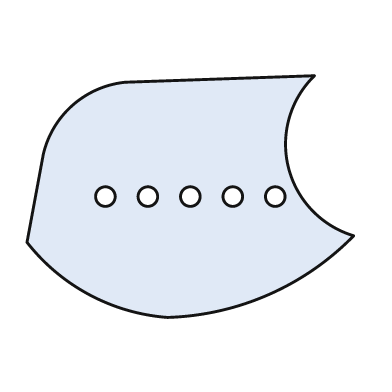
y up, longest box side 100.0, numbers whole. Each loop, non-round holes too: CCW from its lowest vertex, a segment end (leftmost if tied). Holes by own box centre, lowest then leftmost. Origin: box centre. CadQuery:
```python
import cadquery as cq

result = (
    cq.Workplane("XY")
    .moveTo(-7.0, -37.0)
    .threePointArc((24.0, -30.0), (50.0, -12.0))
    .threePointArc((30.0, 9.0), (38.0, 37.0))
    .lineTo(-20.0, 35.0)
    .threePointArc((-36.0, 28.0), (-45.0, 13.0))
    .lineTo(-50.0, -14.0)
    .threePointArc((-31.0, -30.0), (-7.0, -37.0))
    .close()
    .moveTo(-26.0, 0.0)
    .circle(3.0)
    .moveTo(-13.0, 0.0)
    .circle(3.0)
    .moveTo(0.0, 0.0)
    .circle(3.0)
    .moveTo(13.0, 0.0)
    .circle(3.0)
    .moveTo(26.0, 0.0)
    .circle(3.0)
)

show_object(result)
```